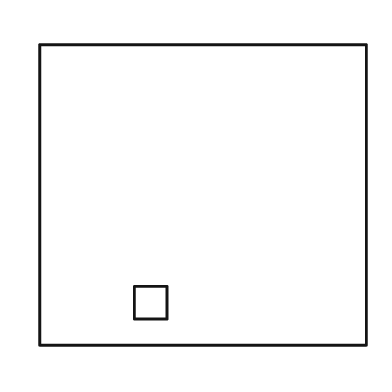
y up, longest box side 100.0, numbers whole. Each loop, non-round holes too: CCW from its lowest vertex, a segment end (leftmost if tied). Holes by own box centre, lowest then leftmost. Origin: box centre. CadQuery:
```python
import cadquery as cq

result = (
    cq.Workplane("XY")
    .moveTo(-50.0, -46.0)
    .lineTo(50.0, -46.0)
    .lineTo(50.0, 46.0)
    .lineTo(-50.0, 46.0)
    .close()
    .moveTo(-21.0, -38.0)
    .lineTo(-11.0, -38.0)
    .lineTo(-11.0, -28.0)
    .lineTo(-21.0, -28.0)
    .close()
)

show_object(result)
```